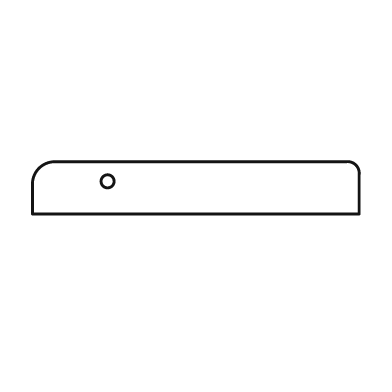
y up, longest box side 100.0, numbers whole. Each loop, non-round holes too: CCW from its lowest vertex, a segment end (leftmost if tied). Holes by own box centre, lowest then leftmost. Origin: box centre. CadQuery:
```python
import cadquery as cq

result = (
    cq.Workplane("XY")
    .moveTo(-50.0, -8.0)
    .lineTo(50.0, -8.0)
    .lineTo(50.0, 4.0)
    .threePointArc((49.0, 7.0), (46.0, 8.0))
    .lineTo(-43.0, 8.0)
    .threePointArc((-48.0, 6.0), (-50.0, 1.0))
    .close()
    .moveTo(-27.0, 2.0)
    .circle(2.0)
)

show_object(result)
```